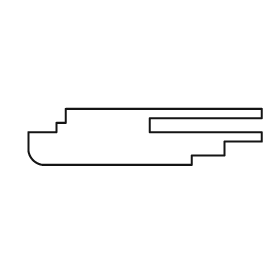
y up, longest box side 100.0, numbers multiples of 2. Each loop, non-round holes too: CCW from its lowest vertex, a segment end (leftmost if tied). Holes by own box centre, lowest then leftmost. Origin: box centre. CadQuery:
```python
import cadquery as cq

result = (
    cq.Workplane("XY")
    .moveTo(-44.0, -12.0)
    .lineTo(20.0, -12.0)
    .lineTo(20.0, -8.0)
    .lineTo(34.0, -8.0)
    .lineTo(34.0, -2.0)
    .lineTo(50.0, -2.0)
    .lineTo(50.0, 2.0)
    .lineTo(2.0, 2.0)
    .lineTo(2.0, 8.0)
    .lineTo(50.0, 8.0)
    .lineTo(50.0, 12.0)
    .lineTo(-34.0, 12.0)
    .lineTo(-34.0, 6.0)
    .lineTo(-38.0, 6.0)
    .lineTo(-38.0, 2.0)
    .lineTo(-50.0, 2.0)
    .lineTo(-50.0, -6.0)
    .threePointArc((-48.0, -10.0), (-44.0, -12.0))
    .close()
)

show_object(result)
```